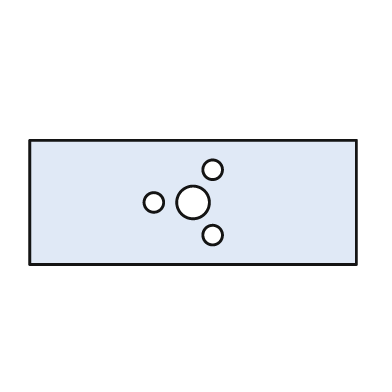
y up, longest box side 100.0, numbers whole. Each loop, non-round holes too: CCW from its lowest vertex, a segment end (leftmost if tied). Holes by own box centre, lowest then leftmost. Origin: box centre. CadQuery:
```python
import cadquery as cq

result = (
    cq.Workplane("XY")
    .moveTo(-50.0, -19.0)
    .lineTo(50.0, -19.0)
    .lineTo(50.0, 19.0)
    .lineTo(-50.0, 19.0)
    .close()
    .moveTo(6.0, -10.0)
    .circle(3.0)
    .moveTo(-12.0, 0.0)
    .circle(3.0)
    .moveTo(0.0, 0.0)
    .circle(5.0)
    .moveTo(6.0, 10.0)
    .circle(3.0)
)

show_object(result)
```